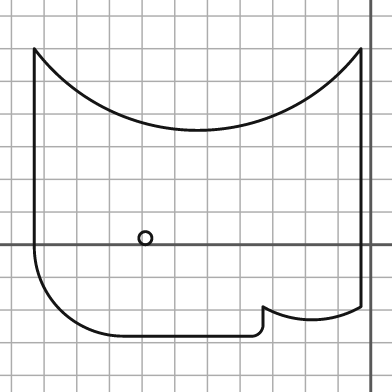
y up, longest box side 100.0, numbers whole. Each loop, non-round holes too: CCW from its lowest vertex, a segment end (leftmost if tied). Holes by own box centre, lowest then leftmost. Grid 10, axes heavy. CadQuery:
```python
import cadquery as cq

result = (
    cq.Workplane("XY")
    .moveTo(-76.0, -28.0)
    .lineTo(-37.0, -28.0)
    .threePointArc((-34.0, -27.0), (-33.0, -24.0))
    .lineTo(-33.0, -19.0)
    .threePointArc((-18.0, -23.0), (-3.0, -19.0))
    .lineTo(-3.0, 60.0)
    .threePointArc((-53.0, 35.0), (-103.0, 60.0))
    .lineTo(-103.0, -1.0)
    .threePointArc((-95.0, -20.0), (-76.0, -28.0))
    .close()
    .moveTo(-69.0, 2.0)
    .circle(2.0)
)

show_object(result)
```